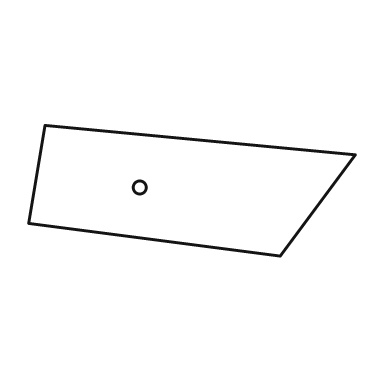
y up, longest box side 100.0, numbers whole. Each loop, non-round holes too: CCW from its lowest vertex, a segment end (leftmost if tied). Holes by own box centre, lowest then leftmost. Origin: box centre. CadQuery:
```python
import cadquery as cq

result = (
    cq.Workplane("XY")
    .moveTo(27.0, -20.0)
    .lineTo(50.0, 11.0)
    .lineTo(-45.0, 20.0)
    .lineTo(-50.0, -10.0)
    .close()
    .moveTo(-16.0, 1.0)
    .circle(2.0)
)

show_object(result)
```